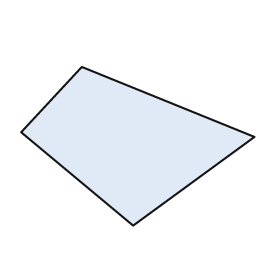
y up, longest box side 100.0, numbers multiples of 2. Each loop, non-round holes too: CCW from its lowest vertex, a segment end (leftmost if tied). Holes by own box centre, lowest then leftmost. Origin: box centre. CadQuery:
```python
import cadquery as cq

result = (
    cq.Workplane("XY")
    .moveTo(-2.0, -34.0)
    .lineTo(50.0, 4.0)
    .lineTo(-24.0, 34.0)
    .lineTo(-50.0, 6.0)
    .close()
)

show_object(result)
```